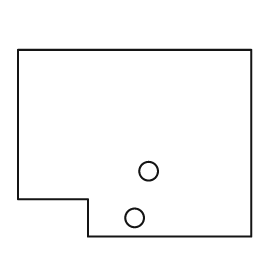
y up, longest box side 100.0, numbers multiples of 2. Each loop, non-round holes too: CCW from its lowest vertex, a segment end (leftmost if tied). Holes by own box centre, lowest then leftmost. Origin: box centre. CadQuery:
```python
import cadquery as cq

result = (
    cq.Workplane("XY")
    .moveTo(-20.0, -40.0)
    .lineTo(50.0, -40.0)
    .lineTo(50.0, 40.0)
    .lineTo(-50.0, 40.0)
    .lineTo(-50.0, -24.0)
    .lineTo(-20.0, -24.0)
    .close()
    .moveTo(0.0, -32.0)
    .circle(4.0)
    .moveTo(6.0, -12.0)
    .circle(4.0)
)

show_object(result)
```